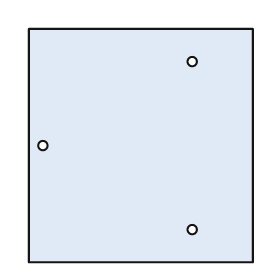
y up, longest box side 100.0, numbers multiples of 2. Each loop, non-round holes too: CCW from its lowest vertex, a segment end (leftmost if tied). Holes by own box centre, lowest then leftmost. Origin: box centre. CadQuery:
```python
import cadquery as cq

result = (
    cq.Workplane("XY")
    .moveTo(-48.0, -50.0)
    .lineTo(48.0, -50.0)
    .lineTo(48.0, 50.0)
    .lineTo(-48.0, 50.0)
    .close()
    .moveTo(22.0, -36.0)
    .circle(2.0)
    .moveTo(-42.0, 0.0)
    .circle(2.0)
    .moveTo(22.0, 36.0)
    .circle(2.0)
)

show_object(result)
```